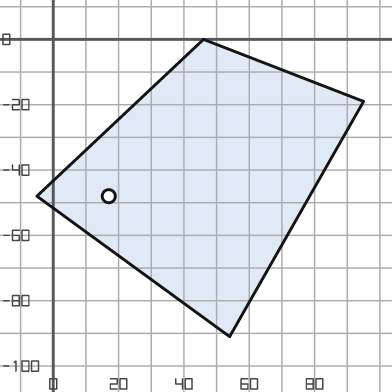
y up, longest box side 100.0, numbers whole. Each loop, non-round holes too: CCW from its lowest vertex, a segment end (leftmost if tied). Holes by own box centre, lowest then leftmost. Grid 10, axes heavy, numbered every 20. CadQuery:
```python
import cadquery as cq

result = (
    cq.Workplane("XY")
    .moveTo(54.0, -91.0)
    .lineTo(95.0, -19.0)
    .lineTo(46.0, 0.0)
    .lineTo(-5.0, -48.0)
    .close()
    .moveTo(17.0, -48.0)
    .circle(2.0)
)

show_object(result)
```